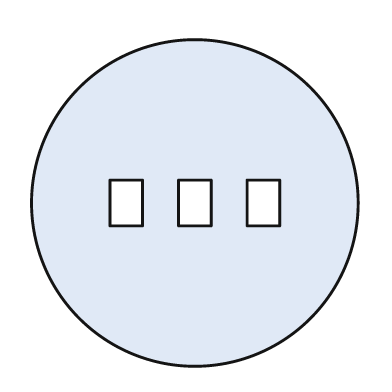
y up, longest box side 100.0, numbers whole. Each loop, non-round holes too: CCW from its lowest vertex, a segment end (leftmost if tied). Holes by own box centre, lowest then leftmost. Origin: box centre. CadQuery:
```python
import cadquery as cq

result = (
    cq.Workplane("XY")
    .moveTo(0.0, 0.0)
    .circle(50.0)
    .moveTo(-26.0, -7.0)
    .lineTo(-16.0, -7.0)
    .lineTo(-16.0, 7.0)
    .lineTo(-26.0, 7.0)
    .close()
    .moveTo(-5.0, -7.0)
    .lineTo(5.0, -7.0)
    .lineTo(5.0, 7.0)
    .lineTo(-5.0, 7.0)
    .close()
    .moveTo(16.0, -7.0)
    .lineTo(26.0, -7.0)
    .lineTo(26.0, 7.0)
    .lineTo(16.0, 7.0)
    .close()
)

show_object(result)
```